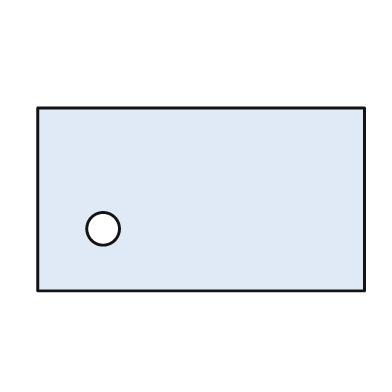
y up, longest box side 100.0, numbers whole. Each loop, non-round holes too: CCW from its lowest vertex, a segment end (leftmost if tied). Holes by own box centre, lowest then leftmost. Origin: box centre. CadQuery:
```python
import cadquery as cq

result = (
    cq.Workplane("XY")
    .moveTo(-50.0, -28.0)
    .lineTo(50.0, -28.0)
    .lineTo(50.0, 28.0)
    .lineTo(-50.0, 28.0)
    .close()
    .moveTo(-30.0, -9.0)
    .circle(5.0)
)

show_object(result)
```